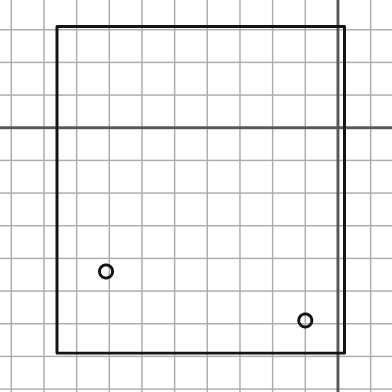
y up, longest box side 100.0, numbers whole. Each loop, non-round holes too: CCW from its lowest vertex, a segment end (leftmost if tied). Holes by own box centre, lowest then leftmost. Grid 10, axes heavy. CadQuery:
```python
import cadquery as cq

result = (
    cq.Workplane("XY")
    .moveTo(-86.0, -69.0)
    .lineTo(2.0, -69.0)
    .lineTo(2.0, 31.0)
    .lineTo(-86.0, 31.0)
    .close()
    .moveTo(-10.0, -59.0)
    .circle(2.0)
    .moveTo(-71.0, -44.0)
    .circle(2.0)
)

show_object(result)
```